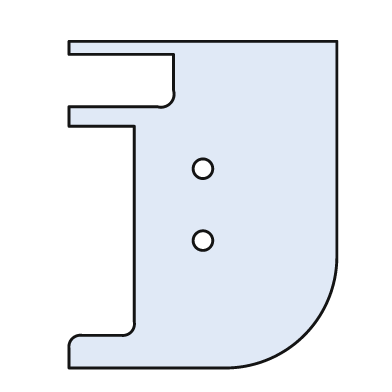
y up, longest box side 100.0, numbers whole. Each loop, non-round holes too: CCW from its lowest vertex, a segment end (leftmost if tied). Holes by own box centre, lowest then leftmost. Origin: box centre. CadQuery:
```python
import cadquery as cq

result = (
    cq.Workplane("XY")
    .moveTo(-41.0, -50.0)
    .lineTo(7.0, -50.0)
    .threePointArc((31.0, -40.0), (41.0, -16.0))
    .lineTo(41.0, 50.0)
    .lineTo(-41.0, 50.0)
    .lineTo(-41.0, 46.0)
    .lineTo(-9.0, 46.0)
    .lineTo(-9.0, 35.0)
    .threePointArc((-10.0, 31.0), (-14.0, 30.0))
    .lineTo(-41.0, 30.0)
    .lineTo(-41.0, 24.0)
    .lineTo(-21.0, 24.0)
    .lineTo(-21.0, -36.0)
    .threePointArc((-22.0, -39.0), (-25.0, -40.0))
    .lineTo(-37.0, -40.0)
    .threePointArc((-40.0, -41.0), (-41.0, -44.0))
    .close()
    .moveTo(0.0, -11.0)
    .circle(3.0)
    .moveTo(0.0, 11.0)
    .circle(3.0)
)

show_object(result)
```